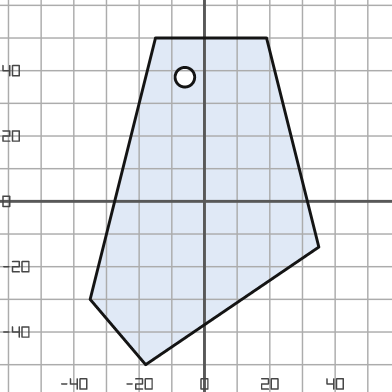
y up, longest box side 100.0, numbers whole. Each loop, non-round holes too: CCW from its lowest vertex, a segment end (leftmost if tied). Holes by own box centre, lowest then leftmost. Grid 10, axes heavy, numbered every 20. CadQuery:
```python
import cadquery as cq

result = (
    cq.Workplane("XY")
    .moveTo(-18.0, -50.0)
    .lineTo(35.0, -14.0)
    .lineTo(19.0, 50.0)
    .lineTo(-15.0, 50.0)
    .lineTo(-35.0, -30.0)
    .close()
    .moveTo(-6.0, 38.0)
    .circle(3.0)
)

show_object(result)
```